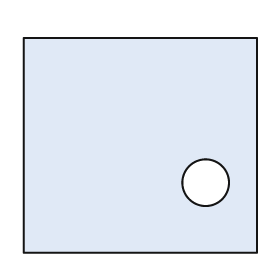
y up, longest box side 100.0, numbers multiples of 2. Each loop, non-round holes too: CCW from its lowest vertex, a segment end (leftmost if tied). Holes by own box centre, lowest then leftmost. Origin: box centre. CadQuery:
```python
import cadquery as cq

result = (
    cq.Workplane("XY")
    .moveTo(-50.0, -46.0)
    .lineTo(50.0, -46.0)
    .lineTo(50.0, 46.0)
    .lineTo(-50.0, 46.0)
    .close()
    .moveTo(28.0, -16.0)
    .circle(10.0)
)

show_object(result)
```